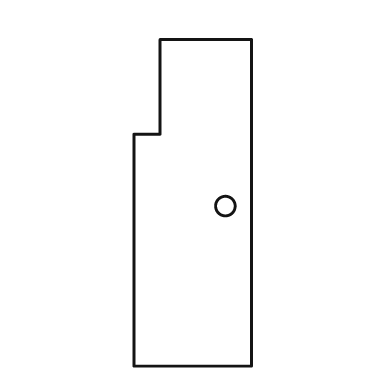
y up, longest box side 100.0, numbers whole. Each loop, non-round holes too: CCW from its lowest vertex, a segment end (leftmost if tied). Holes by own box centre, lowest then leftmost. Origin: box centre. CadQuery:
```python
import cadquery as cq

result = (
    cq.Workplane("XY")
    .moveTo(-18.0, -50.0)
    .lineTo(18.0, -50.0)
    .lineTo(18.0, 50.0)
    .lineTo(-10.0, 50.0)
    .lineTo(-10.0, 21.0)
    .lineTo(-18.0, 21.0)
    .close()
    .moveTo(10.0, -1.0)
    .circle(3.0)
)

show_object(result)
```